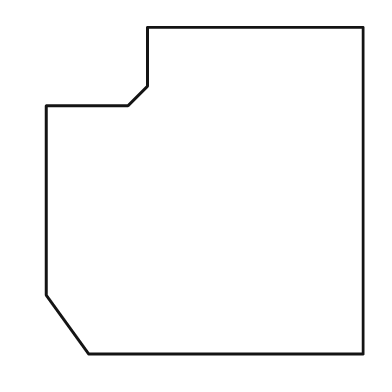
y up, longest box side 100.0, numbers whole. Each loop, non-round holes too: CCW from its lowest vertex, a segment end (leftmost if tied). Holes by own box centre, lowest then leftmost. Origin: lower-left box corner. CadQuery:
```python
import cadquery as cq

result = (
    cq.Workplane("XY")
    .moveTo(13.0, 0.0)
    .lineTo(97.0, 0.0)
    .lineTo(97.0, 100.0)
    .lineTo(31.0, 100.0)
    .lineTo(31.0, 82.0)
    .lineTo(25.0, 76.0)
    .lineTo(0.0, 76.0)
    .lineTo(0.0, 18.0)
    .close()
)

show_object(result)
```